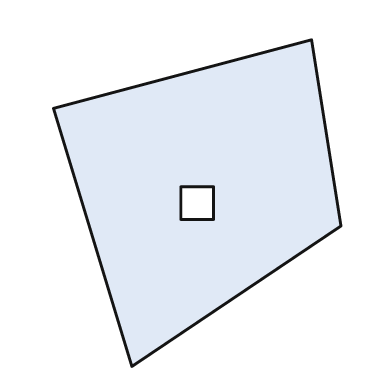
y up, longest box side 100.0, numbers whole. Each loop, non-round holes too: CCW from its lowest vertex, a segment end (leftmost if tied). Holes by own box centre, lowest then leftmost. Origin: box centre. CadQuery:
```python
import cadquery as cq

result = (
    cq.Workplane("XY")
    .moveTo(-20.0, -50.0)
    .lineTo(44.0, -7.0)
    .lineTo(35.0, 50.0)
    .lineTo(-44.0, 29.0)
    .close()
    .moveTo(-5.0, -5.0)
    .lineTo(5.0, -5.0)
    .lineTo(5.0, 5.0)
    .lineTo(-5.0, 5.0)
    .close()
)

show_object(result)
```